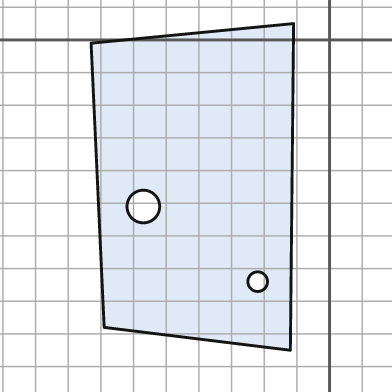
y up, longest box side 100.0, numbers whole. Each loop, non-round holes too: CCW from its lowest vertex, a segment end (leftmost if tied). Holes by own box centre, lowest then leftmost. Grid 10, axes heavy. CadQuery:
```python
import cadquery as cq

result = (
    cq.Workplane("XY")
    .moveTo(-12.0, -95.0)
    .lineTo(-11.0, 5.0)
    .lineTo(-73.0, -1.0)
    .lineTo(-69.0, -88.0)
    .close()
    .moveTo(-22.0, -74.0)
    .circle(3.0)
    .moveTo(-57.0, -51.0)
    .circle(5.0)
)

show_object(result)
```